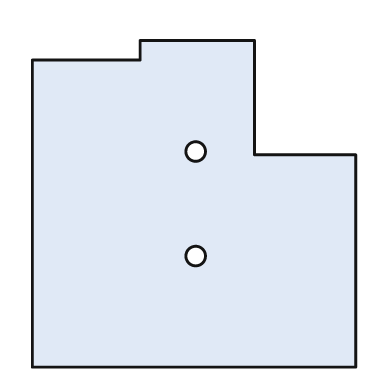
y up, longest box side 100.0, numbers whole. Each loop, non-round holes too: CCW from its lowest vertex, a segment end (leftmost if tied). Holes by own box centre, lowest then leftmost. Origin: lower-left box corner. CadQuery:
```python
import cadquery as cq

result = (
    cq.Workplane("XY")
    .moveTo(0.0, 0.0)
    .lineTo(99.0, 0.0)
    .lineTo(99.0, 65.0)
    .lineTo(68.0, 65.0)
    .lineTo(68.0, 100.0)
    .lineTo(33.0, 100.0)
    .lineTo(33.0, 94.0)
    .lineTo(0.0, 94.0)
    .close()
    .moveTo(50.0, 34.0)
    .circle(3.0)
    .moveTo(50.0, 66.0)
    .circle(3.0)
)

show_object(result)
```